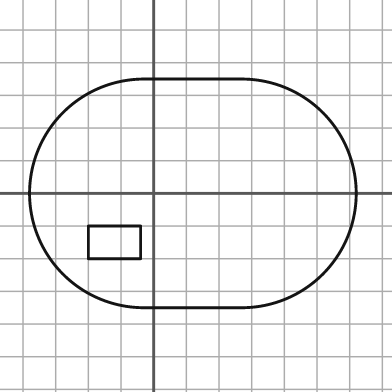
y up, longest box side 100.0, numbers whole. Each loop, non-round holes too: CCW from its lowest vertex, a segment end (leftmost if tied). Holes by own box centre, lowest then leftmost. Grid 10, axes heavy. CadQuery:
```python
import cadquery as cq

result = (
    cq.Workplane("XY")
    .moveTo(-3.0, -35.0)
    .lineTo(27.0, -35.0)
    .threePointArc((62.0, 0.0), (27.0, 35.0))
    .lineTo(-3.0, 35.0)
    .threePointArc((-38.0, 0.0), (-3.0, -35.0))
    .close()
    .moveTo(-20.0, -20.0)
    .lineTo(-4.0, -20.0)
    .lineTo(-4.0, -10.0)
    .lineTo(-20.0, -10.0)
    .close()
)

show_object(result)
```